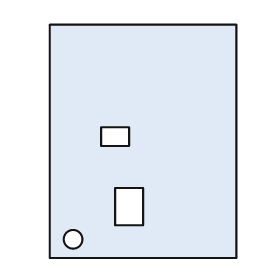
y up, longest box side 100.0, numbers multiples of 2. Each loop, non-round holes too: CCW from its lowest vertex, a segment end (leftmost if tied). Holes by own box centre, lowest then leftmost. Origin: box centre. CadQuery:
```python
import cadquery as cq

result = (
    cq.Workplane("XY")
    .moveTo(-40.0, -50.0)
    .lineTo(40.0, -50.0)
    .lineTo(40.0, 50.0)
    .lineTo(-40.0, 50.0)
    .close()
    .moveTo(-30.0, -42.0)
    .circle(4.0)
    .moveTo(-12.0, -36.0)
    .lineTo(0.0, -36.0)
    .lineTo(0.0, -20.0)
    .lineTo(-12.0, -20.0)
    .close()
    .moveTo(-18.0, -2.0)
    .lineTo(-6.0, -2.0)
    .lineTo(-6.0, 6.0)
    .lineTo(-18.0, 6.0)
    .close()
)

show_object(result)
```